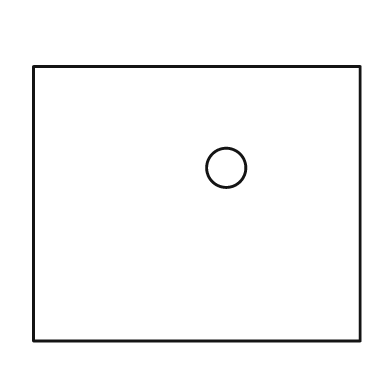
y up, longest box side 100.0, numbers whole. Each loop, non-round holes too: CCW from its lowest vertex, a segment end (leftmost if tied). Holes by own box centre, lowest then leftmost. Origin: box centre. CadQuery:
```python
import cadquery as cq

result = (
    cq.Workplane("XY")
    .moveTo(-50.0, -42.0)
    .lineTo(50.0, -42.0)
    .lineTo(50.0, 42.0)
    .lineTo(-50.0, 42.0)
    .close()
    .moveTo(9.0, 11.0)
    .circle(6.0)
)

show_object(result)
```